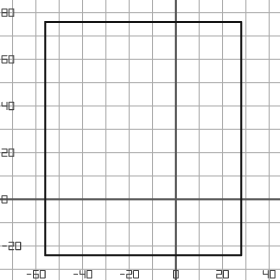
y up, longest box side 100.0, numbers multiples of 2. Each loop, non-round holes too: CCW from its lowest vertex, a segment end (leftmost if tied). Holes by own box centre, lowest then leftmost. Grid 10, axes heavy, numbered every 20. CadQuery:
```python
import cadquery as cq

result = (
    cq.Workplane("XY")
    .moveTo(-56.0, -24.0)
    .lineTo(28.0, -24.0)
    .lineTo(28.0, 76.0)
    .lineTo(-56.0, 76.0)
    .close()
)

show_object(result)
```